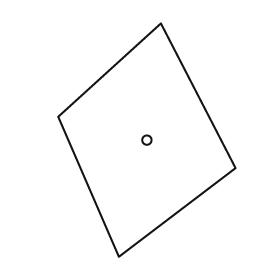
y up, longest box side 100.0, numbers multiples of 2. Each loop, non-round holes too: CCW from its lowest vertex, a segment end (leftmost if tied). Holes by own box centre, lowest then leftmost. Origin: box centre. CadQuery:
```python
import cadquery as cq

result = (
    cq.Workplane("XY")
    .moveTo(-12.0, -50.0)
    .lineTo(38.0, -12.0)
    .lineTo(6.0, 50.0)
    .lineTo(-38.0, 10.0)
    .close()
    .moveTo(0.0, 0.0)
    .circle(2.0)
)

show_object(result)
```